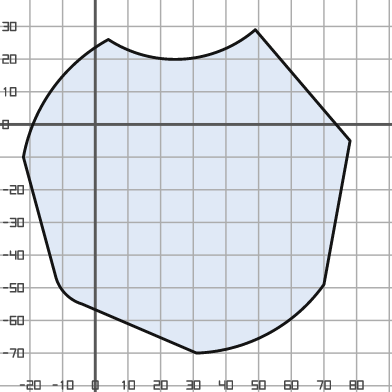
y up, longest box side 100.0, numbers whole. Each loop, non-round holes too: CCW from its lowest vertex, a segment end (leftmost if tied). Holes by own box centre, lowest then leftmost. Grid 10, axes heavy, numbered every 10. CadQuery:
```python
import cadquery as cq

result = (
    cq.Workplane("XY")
    .moveTo(31.0, -70.0)
    .threePointArc((53.0, -64.0), (70.0, -49.0))
    .lineTo(78.0, -5.0)
    .lineTo(49.0, 29.0)
    .threePointArc((27.0, 20.0), (4.0, 26.0))
    .threePointArc((-13.0, 11.0), (-22.0, -10.0))
    .lineTo(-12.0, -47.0)
    .threePointArc((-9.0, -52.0), (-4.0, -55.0))
    .close()
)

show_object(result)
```